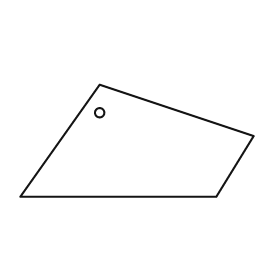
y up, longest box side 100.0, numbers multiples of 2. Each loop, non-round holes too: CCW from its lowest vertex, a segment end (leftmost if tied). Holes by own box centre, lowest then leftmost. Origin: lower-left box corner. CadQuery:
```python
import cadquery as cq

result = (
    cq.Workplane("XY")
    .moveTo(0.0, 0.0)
    .lineTo(84.0, 0.0)
    .lineTo(100.0, 26.0)
    .lineTo(34.0, 48.0)
    .close()
    .moveTo(34.0, 36.0)
    .circle(2.0)
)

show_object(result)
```